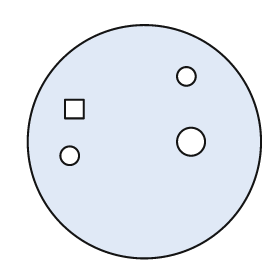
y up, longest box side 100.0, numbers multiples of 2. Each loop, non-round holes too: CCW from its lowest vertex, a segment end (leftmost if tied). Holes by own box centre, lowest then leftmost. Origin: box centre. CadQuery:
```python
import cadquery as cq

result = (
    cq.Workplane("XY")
    .moveTo(0.0, 0.0)
    .circle(50.0)
    .moveTo(-32.0, -6.0)
    .circle(4.0)
    .moveTo(20.0, 0.0)
    .circle(6.0)
    .moveTo(-34.0, 10.0)
    .lineTo(-26.0, 10.0)
    .lineTo(-26.0, 18.0)
    .lineTo(-34.0, 18.0)
    .close()
    .moveTo(18.0, 28.0)
    .circle(4.0)
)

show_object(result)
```